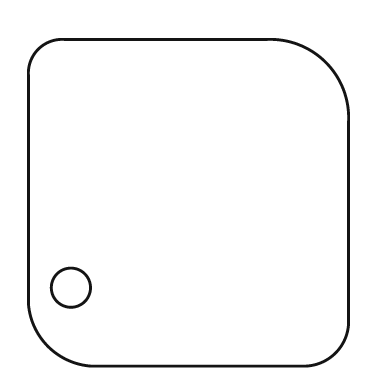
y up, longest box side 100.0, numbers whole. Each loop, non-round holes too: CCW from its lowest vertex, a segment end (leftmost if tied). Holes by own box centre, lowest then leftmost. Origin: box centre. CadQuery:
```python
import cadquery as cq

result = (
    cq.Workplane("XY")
    .moveTo(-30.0, -50.0)
    .lineTo(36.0, -50.0)
    .threePointArc((45.0, -46.0), (49.0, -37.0))
    .lineTo(49.0, 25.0)
    .threePointArc((42.0, 43.0), (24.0, 50.0))
    .lineTo(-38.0, 50.0)
    .threePointArc((-46.0, 47.0), (-49.0, 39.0))
    .lineTo(-49.0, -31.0)
    .threePointArc((-43.0, -44.0), (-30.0, -50.0))
    .close()
    .moveTo(-36.0, -26.0)
    .circle(6.0)
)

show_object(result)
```